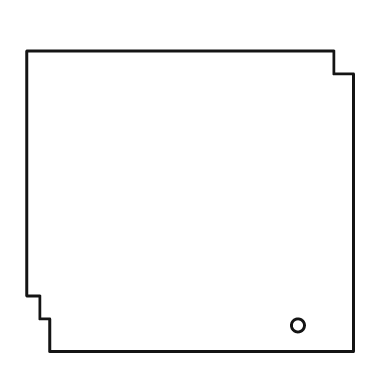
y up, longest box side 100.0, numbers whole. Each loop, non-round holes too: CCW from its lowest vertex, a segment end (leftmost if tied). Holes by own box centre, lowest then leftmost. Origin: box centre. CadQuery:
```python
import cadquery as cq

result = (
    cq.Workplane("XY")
    .moveTo(-43.0, -46.0)
    .lineTo(50.0, -46.0)
    .lineTo(50.0, 39.0)
    .lineTo(44.0, 39.0)
    .lineTo(44.0, 46.0)
    .lineTo(-50.0, 46.0)
    .lineTo(-50.0, -29.0)
    .lineTo(-46.0, -29.0)
    .lineTo(-46.0, -36.0)
    .lineTo(-43.0, -36.0)
    .close()
    .moveTo(33.0, -38.0)
    .circle(2.0)
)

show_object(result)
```